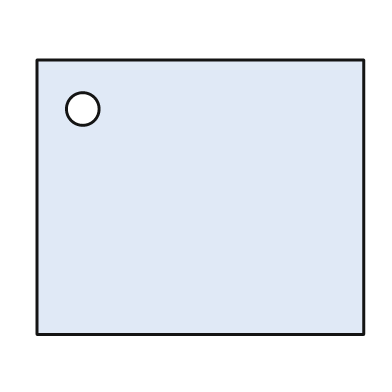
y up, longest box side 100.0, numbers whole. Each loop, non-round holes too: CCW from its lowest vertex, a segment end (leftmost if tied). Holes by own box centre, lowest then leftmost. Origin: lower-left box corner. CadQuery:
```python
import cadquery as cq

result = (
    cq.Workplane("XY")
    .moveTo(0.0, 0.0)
    .lineTo(100.0, 0.0)
    .lineTo(100.0, 84.0)
    .lineTo(0.0, 84.0)
    .close()
    .moveTo(14.0, 69.0)
    .circle(5.0)
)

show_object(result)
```